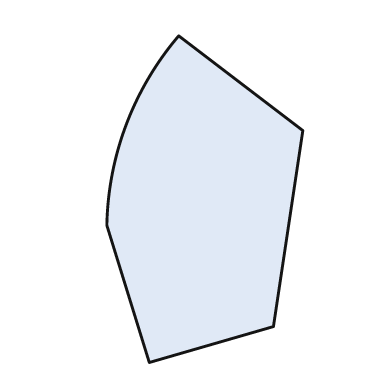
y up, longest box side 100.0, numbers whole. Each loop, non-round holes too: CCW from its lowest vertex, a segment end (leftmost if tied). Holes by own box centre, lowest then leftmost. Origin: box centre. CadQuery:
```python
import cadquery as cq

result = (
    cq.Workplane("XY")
    .moveTo(-17.0, -50.0)
    .lineTo(21.0, -39.0)
    .lineTo(30.0, 21.0)
    .lineTo(-8.0, 50.0)
    .threePointArc((-24.0, 23.0), (-30.0, -8.0))
    .close()
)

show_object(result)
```